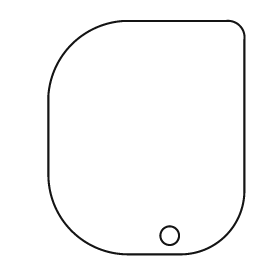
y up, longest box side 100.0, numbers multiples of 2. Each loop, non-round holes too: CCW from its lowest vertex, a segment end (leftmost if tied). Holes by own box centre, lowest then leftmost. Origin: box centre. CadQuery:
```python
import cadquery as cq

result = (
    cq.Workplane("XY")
    .moveTo(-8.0, -50.0)
    .lineTo(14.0, -50.0)
    .threePointArc((34.0, -42.0), (42.0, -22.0))
    .lineTo(42.0, 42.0)
    .threePointArc((40.0, 48.0), (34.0, 50.0))
    .lineTo(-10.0, 50.0)
    .threePointArc((-32.0, 40.0), (-42.0, 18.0))
    .lineTo(-42.0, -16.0)
    .threePointArc((-32.0, -40.0), (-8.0, -50.0))
    .close()
    .moveTo(10.0, -42.0)
    .circle(4.0)
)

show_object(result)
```